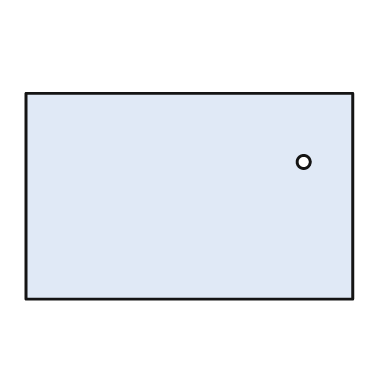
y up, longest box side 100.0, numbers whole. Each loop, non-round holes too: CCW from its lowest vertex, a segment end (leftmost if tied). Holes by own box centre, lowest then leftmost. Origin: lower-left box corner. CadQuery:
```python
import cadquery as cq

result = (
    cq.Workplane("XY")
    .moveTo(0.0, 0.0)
    .lineTo(100.0, 0.0)
    .lineTo(100.0, 63.0)
    .lineTo(0.0, 63.0)
    .close()
    .moveTo(85.0, 42.0)
    .circle(2.0)
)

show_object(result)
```